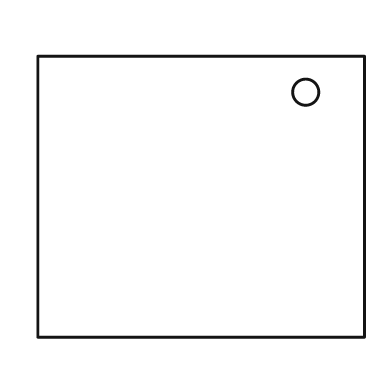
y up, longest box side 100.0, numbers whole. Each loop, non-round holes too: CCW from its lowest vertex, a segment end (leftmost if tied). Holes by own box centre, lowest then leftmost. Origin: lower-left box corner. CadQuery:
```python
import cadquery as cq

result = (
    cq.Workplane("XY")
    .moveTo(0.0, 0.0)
    .lineTo(100.0, 0.0)
    .lineTo(100.0, 86.0)
    .lineTo(0.0, 86.0)
    .close()
    .moveTo(82.0, 75.0)
    .circle(4.0)
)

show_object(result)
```